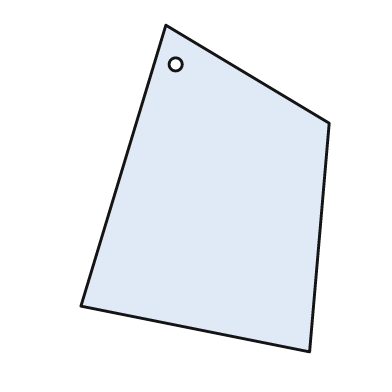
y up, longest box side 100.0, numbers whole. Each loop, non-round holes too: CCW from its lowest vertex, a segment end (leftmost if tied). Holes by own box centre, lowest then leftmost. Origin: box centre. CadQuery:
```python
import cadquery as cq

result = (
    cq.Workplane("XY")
    .moveTo(32.0, -50.0)
    .lineTo(38.0, 20.0)
    .lineTo(-12.0, 50.0)
    .lineTo(-38.0, -36.0)
    .close()
    .moveTo(-9.0, 38.0)
    .circle(2.0)
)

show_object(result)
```